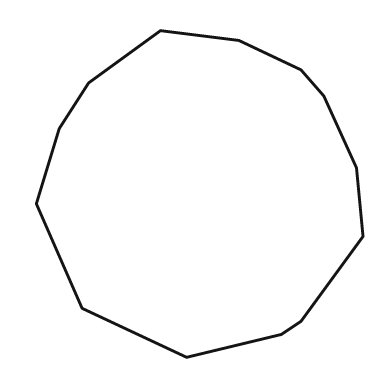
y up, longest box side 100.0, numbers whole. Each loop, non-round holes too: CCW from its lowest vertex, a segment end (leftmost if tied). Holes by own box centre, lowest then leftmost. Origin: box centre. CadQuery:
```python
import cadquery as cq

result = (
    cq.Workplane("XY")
    .moveTo(-4.0, -50.0)
    .lineTo(25.0, -43.0)
    .lineTo(31.0, -39.0)
    .lineTo(50.0, -13.0)
    .lineTo(48.0, 8.0)
    .lineTo(38.0, 30.0)
    .lineTo(31.0, 38.0)
    .lineTo(12.0, 47.0)
    .lineTo(-12.0, 50.0)
    .lineTo(-34.0, 34.0)
    .lineTo(-43.0, 20.0)
    .lineTo(-50.0, -3.0)
    .lineTo(-36.0, -35.0)
    .close()
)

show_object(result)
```